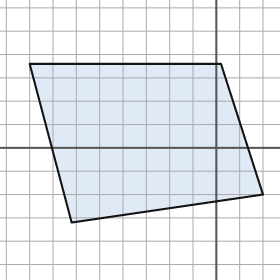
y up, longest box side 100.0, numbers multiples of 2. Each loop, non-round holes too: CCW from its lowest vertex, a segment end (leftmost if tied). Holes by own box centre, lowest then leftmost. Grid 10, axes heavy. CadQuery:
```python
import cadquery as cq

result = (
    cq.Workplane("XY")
    .moveTo(-62.0, -32.0)
    .lineTo(20.0, -20.0)
    .lineTo(2.0, 36.0)
    .lineTo(-80.0, 36.0)
    .close()
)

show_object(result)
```